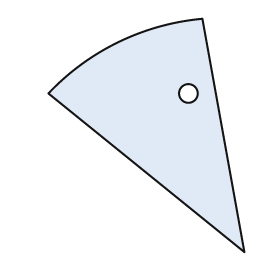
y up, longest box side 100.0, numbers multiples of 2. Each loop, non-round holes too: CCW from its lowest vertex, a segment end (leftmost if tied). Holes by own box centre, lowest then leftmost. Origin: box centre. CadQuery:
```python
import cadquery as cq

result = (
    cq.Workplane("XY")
    .moveTo(42.0, -50.0)
    .lineTo(24.0, 50.0)
    .threePointArc((-12.0, 40.0), (-42.0, 18.0))
    .close()
    .moveTo(18.0, 18.0)
    .circle(4.0)
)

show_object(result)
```